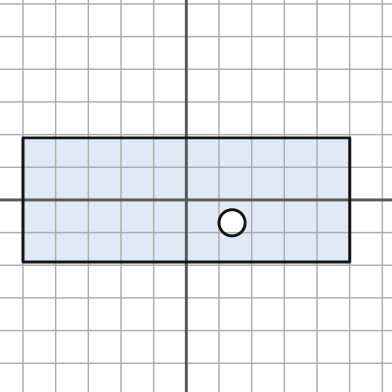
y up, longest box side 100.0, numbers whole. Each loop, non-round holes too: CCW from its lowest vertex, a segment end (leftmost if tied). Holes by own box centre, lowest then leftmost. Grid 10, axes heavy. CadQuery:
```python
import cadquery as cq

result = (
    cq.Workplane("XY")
    .moveTo(-50.0, -19.0)
    .lineTo(50.0, -19.0)
    .lineTo(50.0, 19.0)
    .lineTo(-50.0, 19.0)
    .close()
    .moveTo(14.0, -7.0)
    .circle(4.0)
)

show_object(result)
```